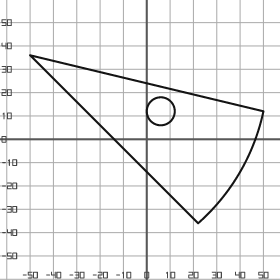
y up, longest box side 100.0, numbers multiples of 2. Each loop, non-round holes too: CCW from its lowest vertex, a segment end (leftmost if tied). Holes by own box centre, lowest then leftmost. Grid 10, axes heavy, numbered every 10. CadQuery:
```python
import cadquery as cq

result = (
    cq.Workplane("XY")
    .moveTo(22.0, -36.0)
    .threePointArc((40.0, -14.0), (50.0, 12.0))
    .lineTo(-50.0, 36.0)
    .close()
    .moveTo(6.0, 12.0)
    .circle(6.0)
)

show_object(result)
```